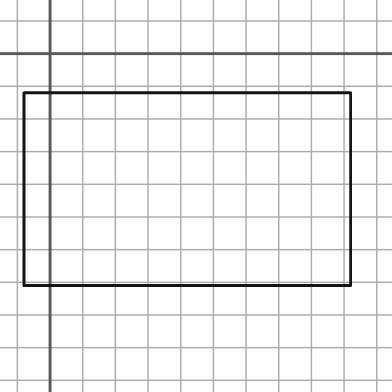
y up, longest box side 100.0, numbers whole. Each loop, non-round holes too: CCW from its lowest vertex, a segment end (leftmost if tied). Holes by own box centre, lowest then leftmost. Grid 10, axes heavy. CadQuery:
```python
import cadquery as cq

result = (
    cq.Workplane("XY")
    .moveTo(-8.0, -71.0)
    .lineTo(92.0, -71.0)
    .lineTo(92.0, -12.0)
    .lineTo(-8.0, -12.0)
    .close()
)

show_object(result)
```